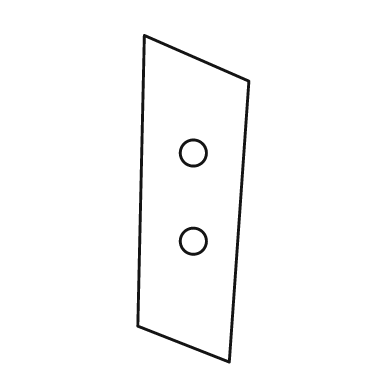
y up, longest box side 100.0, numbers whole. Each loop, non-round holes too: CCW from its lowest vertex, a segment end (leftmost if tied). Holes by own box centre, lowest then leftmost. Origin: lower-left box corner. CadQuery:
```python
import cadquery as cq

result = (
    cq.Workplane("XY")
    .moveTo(28.0, 0.0)
    .lineTo(34.0, 86.0)
    .lineTo(2.0, 100.0)
    .lineTo(0.0, 11.0)
    .close()
    .moveTo(17.0, 37.0)
    .circle(4.0)
    .moveTo(17.0, 64.0)
    .circle(4.0)
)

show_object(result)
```